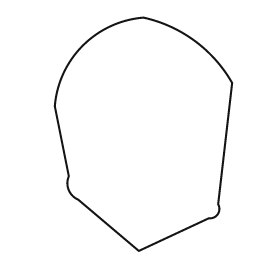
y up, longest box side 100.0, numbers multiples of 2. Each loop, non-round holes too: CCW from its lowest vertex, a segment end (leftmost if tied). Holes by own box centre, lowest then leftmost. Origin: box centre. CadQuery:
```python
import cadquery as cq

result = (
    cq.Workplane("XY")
    .moveTo(-2.0, -50.0)
    .lineTo(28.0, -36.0)
    .threePointArc((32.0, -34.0), (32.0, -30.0))
    .lineTo(38.0, 22.0)
    .threePointArc((22.0, 40.0), (0.0, 50.0))
    .threePointArc((-26.0, 38.0), (-38.0, 12.0))
    .lineTo(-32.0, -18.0)
    .threePointArc((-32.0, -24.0), (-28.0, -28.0))
    .close()
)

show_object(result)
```